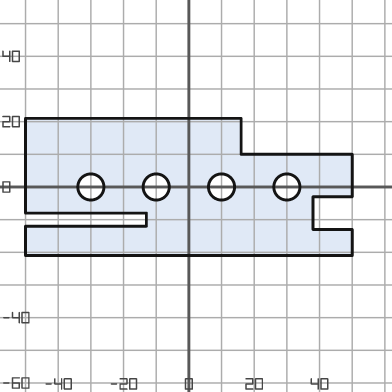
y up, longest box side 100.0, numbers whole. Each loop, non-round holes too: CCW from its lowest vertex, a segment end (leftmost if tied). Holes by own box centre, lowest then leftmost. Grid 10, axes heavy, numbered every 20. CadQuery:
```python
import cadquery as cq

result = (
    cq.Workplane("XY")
    .moveTo(-50.0, -21.0)
    .lineTo(50.0, -21.0)
    .lineTo(50.0, -13.0)
    .lineTo(38.0, -13.0)
    .lineTo(38.0, -3.0)
    .lineTo(50.0, -3.0)
    .lineTo(50.0, 10.0)
    .lineTo(16.0, 10.0)
    .lineTo(16.0, 21.0)
    .lineTo(-50.0, 21.0)
    .lineTo(-50.0, -8.0)
    .lineTo(-13.0, -8.0)
    .lineTo(-13.0, -12.0)
    .lineTo(-50.0, -12.0)
    .close()
    .moveTo(-30.0, 0.0)
    .circle(4.0)
    .moveTo(-10.0, 0.0)
    .circle(4.0)
    .moveTo(10.0, 0.0)
    .circle(4.0)
    .moveTo(30.0, 0.0)
    .circle(4.0)
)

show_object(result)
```